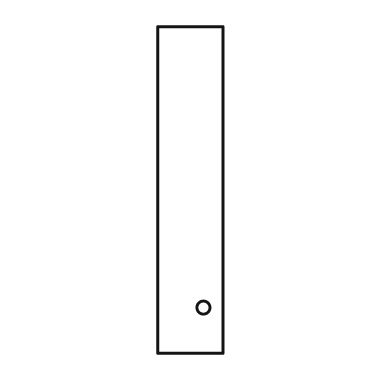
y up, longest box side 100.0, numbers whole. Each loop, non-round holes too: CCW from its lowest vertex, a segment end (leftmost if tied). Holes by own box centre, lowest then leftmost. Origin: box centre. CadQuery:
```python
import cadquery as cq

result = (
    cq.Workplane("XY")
    .moveTo(-10.0, -50.0)
    .lineTo(10.0, -50.0)
    .lineTo(10.0, 50.0)
    .lineTo(-10.0, 50.0)
    .close()
    .moveTo(4.0, -36.0)
    .circle(2.0)
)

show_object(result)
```